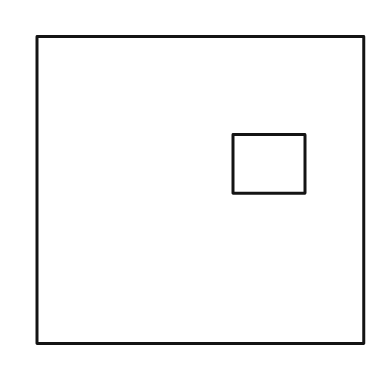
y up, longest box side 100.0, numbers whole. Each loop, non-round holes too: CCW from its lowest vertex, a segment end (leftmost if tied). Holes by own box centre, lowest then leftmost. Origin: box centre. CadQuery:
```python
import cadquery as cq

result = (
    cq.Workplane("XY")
    .moveTo(-50.0, -47.0)
    .lineTo(50.0, -47.0)
    .lineTo(50.0, 47.0)
    .lineTo(-50.0, 47.0)
    .close()
    .moveTo(10.0, -1.0)
    .lineTo(32.0, -1.0)
    .lineTo(32.0, 17.0)
    .lineTo(10.0, 17.0)
    .close()
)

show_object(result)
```